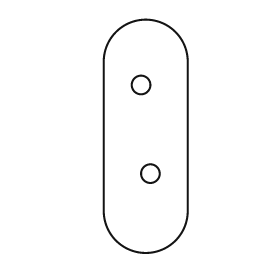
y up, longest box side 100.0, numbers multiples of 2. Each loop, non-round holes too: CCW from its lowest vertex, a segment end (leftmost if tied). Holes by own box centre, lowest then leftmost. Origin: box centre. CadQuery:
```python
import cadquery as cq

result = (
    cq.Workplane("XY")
    .moveTo(-18.0, -32.0)
    .threePointArc((0.0, -50.0), (18.0, -32.0))
    .lineTo(18.0, 32.0)
    .threePointArc((0.0, 50.0), (-18.0, 32.0))
    .close()
    .moveTo(2.0, -16.0)
    .circle(4.0)
    .moveTo(-2.0, 22.0)
    .circle(4.0)
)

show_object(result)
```